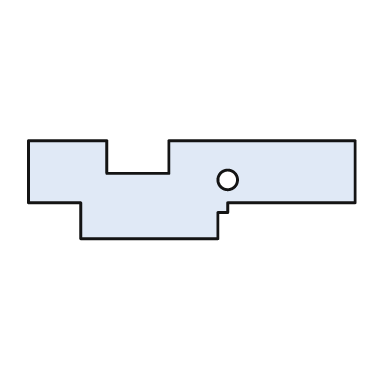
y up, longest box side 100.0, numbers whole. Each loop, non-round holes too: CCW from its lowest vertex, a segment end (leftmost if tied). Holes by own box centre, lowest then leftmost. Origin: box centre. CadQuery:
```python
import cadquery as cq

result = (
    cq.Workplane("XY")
    .moveTo(-34.0, -15.0)
    .lineTo(8.0, -15.0)
    .lineTo(8.0, -7.0)
    .lineTo(11.0, -7.0)
    .lineTo(11.0, -4.0)
    .lineTo(50.0, -4.0)
    .lineTo(50.0, 15.0)
    .lineTo(-7.0, 15.0)
    .lineTo(-7.0, 5.0)
    .lineTo(-26.0, 5.0)
    .lineTo(-26.0, 15.0)
    .lineTo(-50.0, 15.0)
    .lineTo(-50.0, -4.0)
    .lineTo(-34.0, -4.0)
    .close()
    .moveTo(11.0, 3.0)
    .circle(3.0)
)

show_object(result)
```